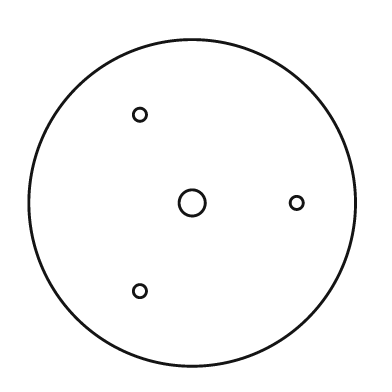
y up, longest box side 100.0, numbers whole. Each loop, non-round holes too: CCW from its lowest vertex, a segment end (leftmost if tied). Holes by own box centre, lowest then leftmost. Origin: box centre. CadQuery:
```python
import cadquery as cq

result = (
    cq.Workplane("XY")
    .moveTo(0.0, 0.0)
    .circle(50.0)
    .moveTo(-16.0, -27.0)
    .circle(2.0)
    .moveTo(0.0, 0.0)
    .circle(4.0)
    .moveTo(32.0, 0.0)
    .circle(2.0)
    .moveTo(-16.0, 27.0)
    .circle(2.0)
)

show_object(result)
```